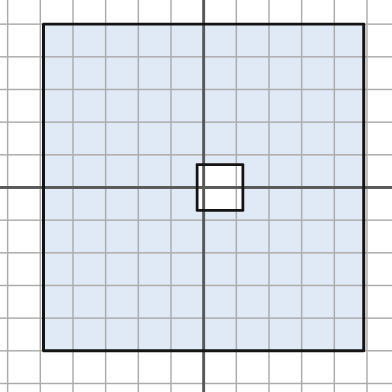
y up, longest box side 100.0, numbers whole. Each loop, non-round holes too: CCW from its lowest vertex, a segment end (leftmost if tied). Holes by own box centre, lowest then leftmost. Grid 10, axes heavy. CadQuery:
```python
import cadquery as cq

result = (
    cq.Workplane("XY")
    .moveTo(-49.0, -50.0)
    .lineTo(49.0, -50.0)
    .lineTo(49.0, 50.0)
    .lineTo(-49.0, 50.0)
    .close()
    .moveTo(-2.0, -7.0)
    .lineTo(12.0, -7.0)
    .lineTo(12.0, 7.0)
    .lineTo(-2.0, 7.0)
    .close()
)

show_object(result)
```